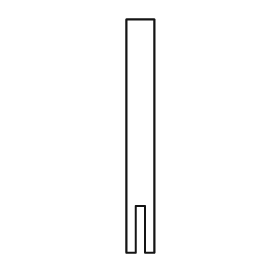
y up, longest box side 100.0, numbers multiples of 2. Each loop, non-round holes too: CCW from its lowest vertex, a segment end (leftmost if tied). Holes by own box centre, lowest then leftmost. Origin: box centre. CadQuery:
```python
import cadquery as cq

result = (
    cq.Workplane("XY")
    .moveTo(-6.0, -50.0)
    .lineTo(-2.0, -50.0)
    .lineTo(-2.0, -30.0)
    .lineTo(2.0, -30.0)
    .lineTo(2.0, -50.0)
    .lineTo(6.0, -50.0)
    .lineTo(6.0, 50.0)
    .lineTo(-6.0, 50.0)
    .close()
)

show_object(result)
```